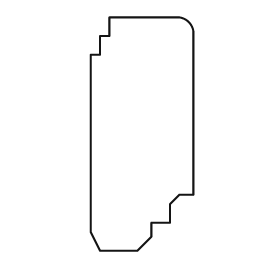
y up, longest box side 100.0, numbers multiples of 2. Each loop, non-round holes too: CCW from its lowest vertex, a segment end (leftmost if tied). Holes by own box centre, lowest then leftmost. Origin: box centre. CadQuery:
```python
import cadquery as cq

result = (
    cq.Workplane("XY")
    .moveTo(-18.0, -50.0)
    .lineTo(-2.0, -50.0)
    .lineTo(4.0, -44.0)
    .lineTo(4.0, -38.0)
    .lineTo(12.0, -38.0)
    .lineTo(12.0, -30.0)
    .lineTo(16.0, -26.0)
    .lineTo(22.0, -26.0)
    .lineTo(22.0, 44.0)
    .threePointArc((20.0, 48.0), (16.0, 50.0))
    .lineTo(-14.0, 50.0)
    .lineTo(-14.0, 42.0)
    .lineTo(-18.0, 42.0)
    .lineTo(-18.0, 34.0)
    .lineTo(-22.0, 34.0)
    .lineTo(-22.0, -42.0)
    .close()
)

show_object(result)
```